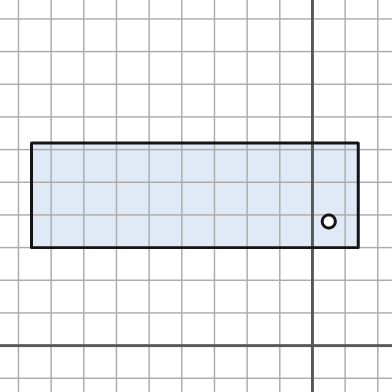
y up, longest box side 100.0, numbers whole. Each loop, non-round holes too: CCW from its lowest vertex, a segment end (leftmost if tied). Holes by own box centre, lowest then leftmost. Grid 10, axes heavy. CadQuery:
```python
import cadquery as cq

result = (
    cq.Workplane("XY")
    .moveTo(-86.0, 30.0)
    .lineTo(14.0, 30.0)
    .lineTo(14.0, 62.0)
    .lineTo(-86.0, 62.0)
    .close()
    .moveTo(5.0, 38.0)
    .circle(2.0)
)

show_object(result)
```